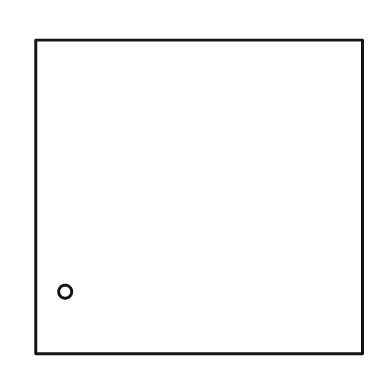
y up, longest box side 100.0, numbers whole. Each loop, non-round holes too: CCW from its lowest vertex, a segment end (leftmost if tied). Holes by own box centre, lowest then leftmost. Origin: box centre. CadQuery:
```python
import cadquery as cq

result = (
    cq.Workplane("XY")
    .moveTo(-50.0, -48.0)
    .lineTo(50.0, -48.0)
    .lineTo(50.0, 48.0)
    .lineTo(-50.0, 48.0)
    .close()
    .moveTo(-41.0, -29.0)
    .circle(2.0)
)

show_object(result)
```